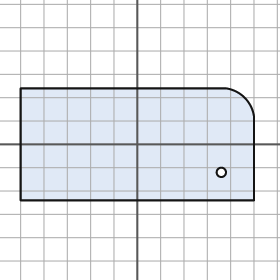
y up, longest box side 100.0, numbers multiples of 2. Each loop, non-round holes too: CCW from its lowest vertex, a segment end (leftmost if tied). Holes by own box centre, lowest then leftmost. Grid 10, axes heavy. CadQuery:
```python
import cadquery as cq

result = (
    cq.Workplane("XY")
    .moveTo(-50.0, -24.0)
    .lineTo(50.0, -24.0)
    .lineTo(50.0, 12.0)
    .threePointArc((46.0, 20.0), (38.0, 24.0))
    .lineTo(-50.0, 24.0)
    .close()
    .moveTo(36.0, -12.0)
    .circle(2.0)
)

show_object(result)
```